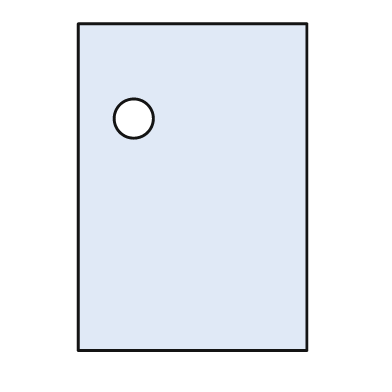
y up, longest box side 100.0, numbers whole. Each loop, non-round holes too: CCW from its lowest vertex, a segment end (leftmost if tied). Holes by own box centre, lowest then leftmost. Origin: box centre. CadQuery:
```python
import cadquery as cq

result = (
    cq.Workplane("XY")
    .moveTo(-35.0, -50.0)
    .lineTo(35.0, -50.0)
    .lineTo(35.0, 50.0)
    .lineTo(-35.0, 50.0)
    .close()
    .moveTo(-18.0, 21.0)
    .circle(6.0)
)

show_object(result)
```